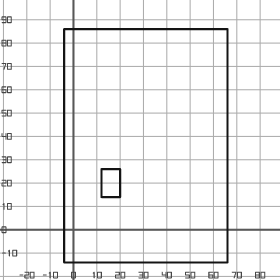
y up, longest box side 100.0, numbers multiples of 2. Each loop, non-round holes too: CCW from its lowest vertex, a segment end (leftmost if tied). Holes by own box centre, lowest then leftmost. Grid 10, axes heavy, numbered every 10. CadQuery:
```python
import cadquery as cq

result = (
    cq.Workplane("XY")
    .moveTo(-4.0, -14.0)
    .lineTo(66.0, -14.0)
    .lineTo(66.0, 86.0)
    .lineTo(-4.0, 86.0)
    .close()
    .moveTo(12.0, 14.0)
    .lineTo(20.0, 14.0)
    .lineTo(20.0, 26.0)
    .lineTo(12.0, 26.0)
    .close()
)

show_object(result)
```